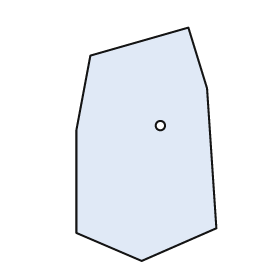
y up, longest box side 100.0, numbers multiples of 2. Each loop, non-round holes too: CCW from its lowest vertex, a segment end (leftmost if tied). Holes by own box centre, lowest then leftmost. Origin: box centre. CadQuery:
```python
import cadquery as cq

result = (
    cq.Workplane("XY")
    .moveTo(-2.0, -50.0)
    .lineTo(30.0, -36.0)
    .lineTo(26.0, 24.0)
    .lineTo(18.0, 50.0)
    .lineTo(-24.0, 38.0)
    .lineTo(-30.0, 6.0)
    .lineTo(-30.0, -38.0)
    .close()
    .moveTo(6.0, 8.0)
    .circle(2.0)
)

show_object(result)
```